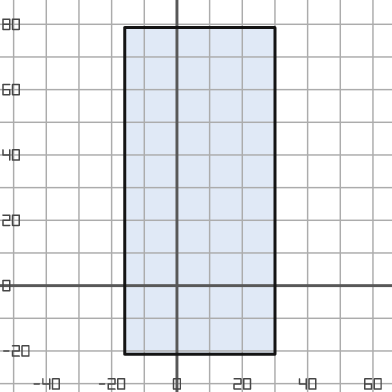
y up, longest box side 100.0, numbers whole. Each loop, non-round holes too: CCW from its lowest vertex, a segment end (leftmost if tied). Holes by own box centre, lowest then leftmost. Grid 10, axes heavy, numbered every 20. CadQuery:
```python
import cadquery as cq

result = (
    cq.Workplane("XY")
    .moveTo(-16.0, -21.0)
    .lineTo(30.0, -21.0)
    .lineTo(30.0, 79.0)
    .lineTo(-16.0, 79.0)
    .close()
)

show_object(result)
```